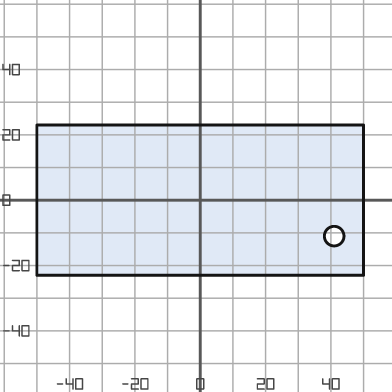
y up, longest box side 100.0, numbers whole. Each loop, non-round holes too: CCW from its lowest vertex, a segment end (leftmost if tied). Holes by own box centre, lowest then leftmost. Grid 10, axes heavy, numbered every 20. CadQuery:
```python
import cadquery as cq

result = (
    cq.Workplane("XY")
    .moveTo(-50.0, -23.0)
    .lineTo(50.0, -23.0)
    .lineTo(50.0, 23.0)
    .lineTo(-50.0, 23.0)
    .close()
    .moveTo(41.0, -11.0)
    .circle(3.0)
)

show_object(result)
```